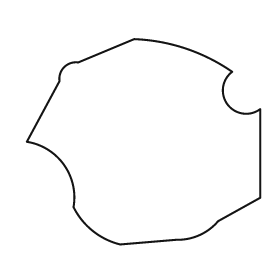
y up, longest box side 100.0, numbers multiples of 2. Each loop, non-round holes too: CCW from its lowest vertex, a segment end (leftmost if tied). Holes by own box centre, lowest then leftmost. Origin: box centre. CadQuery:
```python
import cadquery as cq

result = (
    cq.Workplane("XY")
    .moveTo(-10.0, -44.0)
    .lineTo(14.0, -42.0)
    .threePointArc((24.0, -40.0), (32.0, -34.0))
    .lineTo(50.0, -24.0)
    .lineTo(50.0, 14.0)
    .threePointArc((36.0, 16.0), (38.0, 30.0))
    .threePointArc((18.0, 40.0), (-4.0, 44.0))
    .lineTo(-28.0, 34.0)
    .threePointArc((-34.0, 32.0), (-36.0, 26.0))
    .lineTo(-50.0, 0.0)
    .threePointArc((-34.0, -10.0), (-30.0, -28.0))
    .threePointArc((-22.0, -38.0), (-10.0, -44.0))
    .close()
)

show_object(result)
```